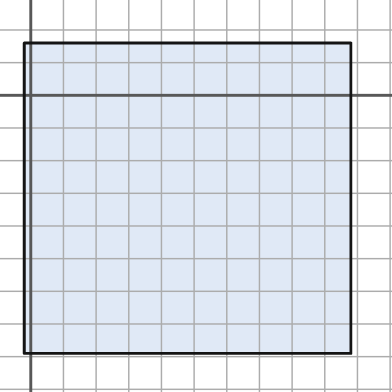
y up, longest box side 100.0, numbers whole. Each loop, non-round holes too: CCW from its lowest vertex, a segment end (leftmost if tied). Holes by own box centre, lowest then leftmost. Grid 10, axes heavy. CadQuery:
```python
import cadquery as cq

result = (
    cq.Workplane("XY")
    .moveTo(-2.0, -79.0)
    .lineTo(98.0, -79.0)
    .lineTo(98.0, 16.0)
    .lineTo(-2.0, 16.0)
    .close()
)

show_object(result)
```